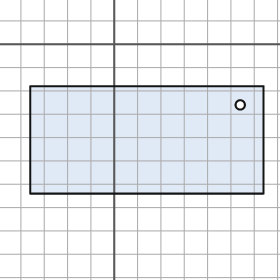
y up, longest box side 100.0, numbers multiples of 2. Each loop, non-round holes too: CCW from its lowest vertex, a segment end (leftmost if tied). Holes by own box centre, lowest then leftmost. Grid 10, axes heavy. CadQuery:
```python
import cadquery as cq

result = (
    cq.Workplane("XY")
    .moveTo(-36.0, -64.0)
    .lineTo(64.0, -64.0)
    .lineTo(64.0, -18.0)
    .lineTo(-36.0, -18.0)
    .close()
    .moveTo(54.0, -26.0)
    .circle(2.0)
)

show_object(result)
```